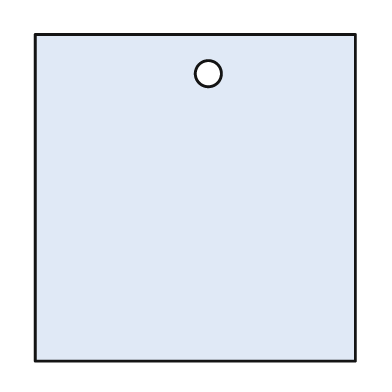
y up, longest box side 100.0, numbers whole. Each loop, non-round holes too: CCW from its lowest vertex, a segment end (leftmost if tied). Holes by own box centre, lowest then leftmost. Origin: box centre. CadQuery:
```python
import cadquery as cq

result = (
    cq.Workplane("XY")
    .moveTo(-49.0, -50.0)
    .lineTo(49.0, -50.0)
    .lineTo(49.0, 50.0)
    .lineTo(-49.0, 50.0)
    .close()
    .moveTo(4.0, 38.0)
    .circle(4.0)
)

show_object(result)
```